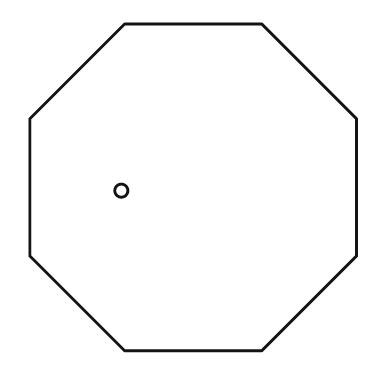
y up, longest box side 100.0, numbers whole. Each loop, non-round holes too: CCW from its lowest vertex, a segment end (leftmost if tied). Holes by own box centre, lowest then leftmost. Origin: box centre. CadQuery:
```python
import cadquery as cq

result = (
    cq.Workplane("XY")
    .moveTo(-21.0, -50.0)
    .lineTo(21.0, -50.0)
    .lineTo(50.0, -21.0)
    .lineTo(50.0, 21.0)
    .lineTo(21.0, 50.0)
    .lineTo(-21.0, 50.0)
    .lineTo(-50.0, 21.0)
    .lineTo(-50.0, -21.0)
    .close()
    .moveTo(-22.0, -1.0)
    .circle(2.0)
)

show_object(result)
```